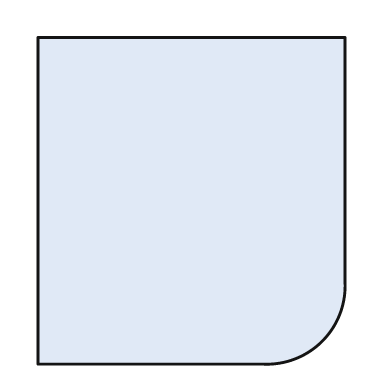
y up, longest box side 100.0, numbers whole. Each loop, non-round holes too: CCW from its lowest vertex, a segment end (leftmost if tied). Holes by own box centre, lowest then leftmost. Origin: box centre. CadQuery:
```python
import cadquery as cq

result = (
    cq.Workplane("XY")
    .moveTo(-47.0, -50.0)
    .lineTo(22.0, -50.0)
    .threePointArc((40.0, -43.0), (47.0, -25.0))
    .lineTo(47.0, 50.0)
    .lineTo(-47.0, 50.0)
    .close()
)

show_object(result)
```